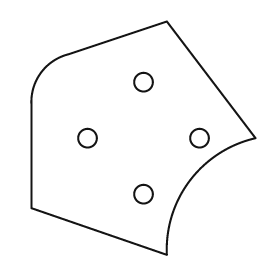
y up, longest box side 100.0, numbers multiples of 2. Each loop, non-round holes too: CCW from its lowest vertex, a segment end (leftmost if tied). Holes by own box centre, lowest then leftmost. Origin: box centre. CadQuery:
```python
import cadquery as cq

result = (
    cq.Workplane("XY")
    .moveTo(10.0, -50.0)
    .threePointArc((20.0, -18.0), (48.0, 0.0))
    .lineTo(10.0, 50.0)
    .lineTo(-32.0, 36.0)
    .threePointArc((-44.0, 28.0), (-48.0, 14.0))
    .lineTo(-48.0, -30.0)
    .close()
    .moveTo(0.0, -24.0)
    .circle(4.0)
    .moveTo(-24.0, 0.0)
    .circle(4.0)
    .moveTo(24.0, 0.0)
    .circle(4.0)
    .moveTo(0.0, 24.0)
    .circle(4.0)
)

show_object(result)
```